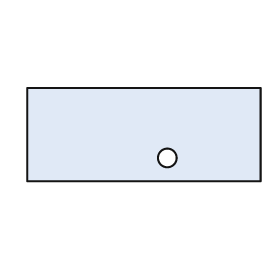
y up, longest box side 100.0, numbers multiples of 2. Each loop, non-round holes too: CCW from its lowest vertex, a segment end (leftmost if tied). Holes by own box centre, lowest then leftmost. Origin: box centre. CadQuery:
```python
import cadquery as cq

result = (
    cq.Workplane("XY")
    .moveTo(-50.0, -20.0)
    .lineTo(50.0, -20.0)
    .lineTo(50.0, 20.0)
    .lineTo(-50.0, 20.0)
    .close()
    .moveTo(10.0, -10.0)
    .circle(4.0)
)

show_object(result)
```